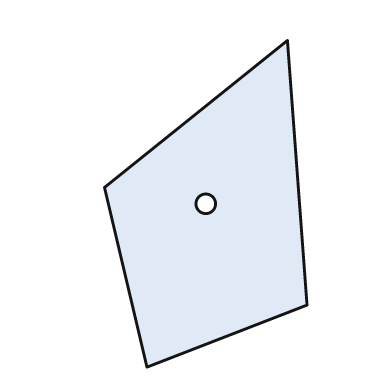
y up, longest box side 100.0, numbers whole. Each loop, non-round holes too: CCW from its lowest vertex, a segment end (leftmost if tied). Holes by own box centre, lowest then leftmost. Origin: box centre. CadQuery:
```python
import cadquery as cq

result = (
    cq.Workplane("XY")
    .moveTo(-18.0, -50.0)
    .lineTo(31.0, -31.0)
    .lineTo(25.0, 50.0)
    .lineTo(-31.0, 5.0)
    .close()
    .moveTo(0.0, 0.0)
    .circle(3.0)
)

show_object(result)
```